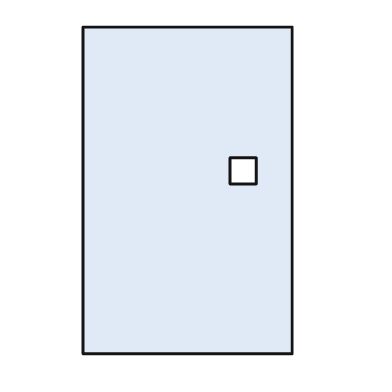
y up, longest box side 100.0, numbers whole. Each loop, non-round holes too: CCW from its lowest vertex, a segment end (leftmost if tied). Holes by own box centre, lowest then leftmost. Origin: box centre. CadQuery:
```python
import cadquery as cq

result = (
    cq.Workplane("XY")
    .moveTo(-32.0, -50.0)
    .lineTo(32.0, -50.0)
    .lineTo(32.0, 50.0)
    .lineTo(-32.0, 50.0)
    .close()
    .moveTo(13.0, 2.0)
    .lineTo(21.0, 2.0)
    .lineTo(21.0, 10.0)
    .lineTo(13.0, 10.0)
    .close()
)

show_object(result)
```